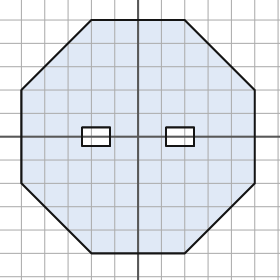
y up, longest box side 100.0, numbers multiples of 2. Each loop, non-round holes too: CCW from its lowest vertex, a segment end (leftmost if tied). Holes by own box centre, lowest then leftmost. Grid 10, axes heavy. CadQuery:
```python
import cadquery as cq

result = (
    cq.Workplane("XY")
    .moveTo(-20.0, -50.0)
    .lineTo(20.0, -50.0)
    .lineTo(50.0, -20.0)
    .lineTo(50.0, 20.0)
    .lineTo(20.0, 50.0)
    .lineTo(-20.0, 50.0)
    .lineTo(-50.0, 20.0)
    .lineTo(-50.0, -20.0)
    .close()
    .moveTo(-24.0, -4.0)
    .lineTo(-12.0, -4.0)
    .lineTo(-12.0, 4.0)
    .lineTo(-24.0, 4.0)
    .close()
    .moveTo(12.0, -4.0)
    .lineTo(24.0, -4.0)
    .lineTo(24.0, 4.0)
    .lineTo(12.0, 4.0)
    .close()
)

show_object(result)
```